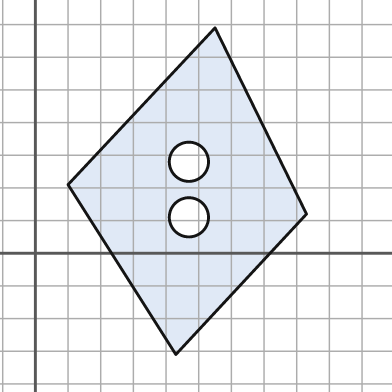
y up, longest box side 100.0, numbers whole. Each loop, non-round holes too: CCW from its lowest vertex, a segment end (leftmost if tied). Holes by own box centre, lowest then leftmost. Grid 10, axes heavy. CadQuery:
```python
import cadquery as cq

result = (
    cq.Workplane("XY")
    .moveTo(43.0, -31.0)
    .lineTo(83.0, 12.0)
    .lineTo(55.0, 69.0)
    .lineTo(10.0, 21.0)
    .close()
    .moveTo(47.0, 11.0)
    .circle(6.0)
    .moveTo(47.0, 28.0)
    .circle(6.0)
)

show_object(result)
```